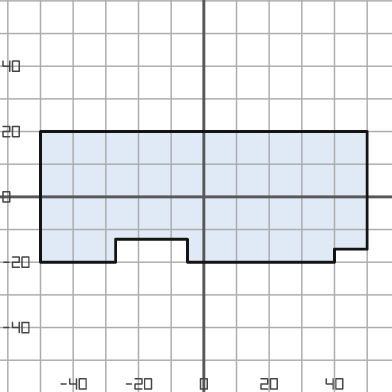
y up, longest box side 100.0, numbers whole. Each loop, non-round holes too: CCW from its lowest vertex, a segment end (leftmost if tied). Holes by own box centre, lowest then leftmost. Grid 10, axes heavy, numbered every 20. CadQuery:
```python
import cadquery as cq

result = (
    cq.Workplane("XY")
    .moveTo(-50.0, -20.0)
    .lineTo(-27.0, -20.0)
    .lineTo(-27.0, -13.0)
    .lineTo(-5.0, -13.0)
    .lineTo(-5.0, -20.0)
    .lineTo(40.0, -20.0)
    .lineTo(40.0, -16.0)
    .lineTo(50.0, -16.0)
    .lineTo(50.0, 20.0)
    .lineTo(-50.0, 20.0)
    .close()
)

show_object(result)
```